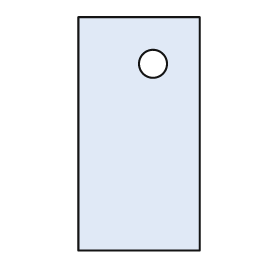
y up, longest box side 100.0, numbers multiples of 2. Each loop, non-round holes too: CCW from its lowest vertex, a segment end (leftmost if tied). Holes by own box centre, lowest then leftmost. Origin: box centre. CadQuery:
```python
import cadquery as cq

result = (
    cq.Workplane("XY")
    .moveTo(-26.0, -50.0)
    .lineTo(26.0, -50.0)
    .lineTo(26.0, 50.0)
    .lineTo(-26.0, 50.0)
    .close()
    .moveTo(6.0, 30.0)
    .circle(6.0)
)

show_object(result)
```